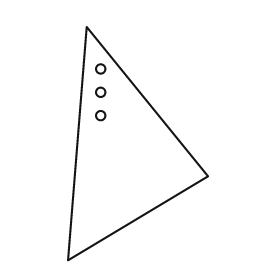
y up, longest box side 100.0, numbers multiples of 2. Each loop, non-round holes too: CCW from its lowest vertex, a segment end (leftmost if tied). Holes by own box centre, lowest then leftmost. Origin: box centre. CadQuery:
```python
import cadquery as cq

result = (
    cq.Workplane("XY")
    .moveTo(-30.0, -50.0)
    .lineTo(30.0, -14.0)
    .lineTo(-22.0, 50.0)
    .close()
    .moveTo(-16.0, 12.0)
    .circle(2.0)
    .moveTo(-16.0, 22.0)
    .circle(2.0)
    .moveTo(-16.0, 32.0)
    .circle(2.0)
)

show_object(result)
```